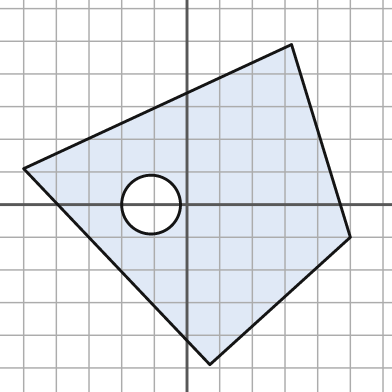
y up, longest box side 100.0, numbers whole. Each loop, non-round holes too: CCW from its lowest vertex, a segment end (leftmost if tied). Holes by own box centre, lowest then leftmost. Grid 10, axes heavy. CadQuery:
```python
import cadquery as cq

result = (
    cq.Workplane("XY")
    .moveTo(7.0, -49.0)
    .lineTo(50.0, -10.0)
    .lineTo(32.0, 49.0)
    .lineTo(-50.0, 11.0)
    .close()
    .moveTo(-11.0, 0.0)
    .circle(9.0)
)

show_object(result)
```